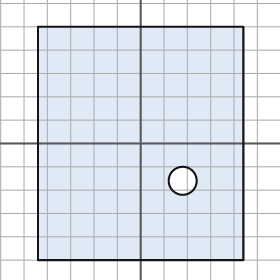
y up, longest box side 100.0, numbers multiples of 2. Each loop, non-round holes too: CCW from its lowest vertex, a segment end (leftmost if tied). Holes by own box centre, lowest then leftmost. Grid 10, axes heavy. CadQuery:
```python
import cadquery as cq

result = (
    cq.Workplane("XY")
    .moveTo(-44.0, -50.0)
    .lineTo(44.0, -50.0)
    .lineTo(44.0, 50.0)
    .lineTo(-44.0, 50.0)
    .close()
    .moveTo(18.0, -16.0)
    .circle(6.0)
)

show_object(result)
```